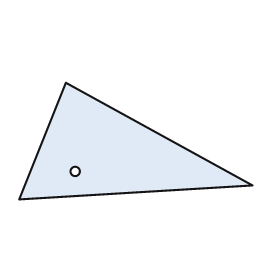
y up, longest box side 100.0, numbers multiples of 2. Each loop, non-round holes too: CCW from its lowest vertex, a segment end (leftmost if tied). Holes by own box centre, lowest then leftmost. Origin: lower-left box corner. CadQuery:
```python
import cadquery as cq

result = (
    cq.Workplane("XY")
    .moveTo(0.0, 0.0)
    .lineTo(100.0, 6.0)
    .lineTo(20.0, 50.0)
    .close()
    .moveTo(24.0, 12.0)
    .circle(2.0)
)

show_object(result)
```